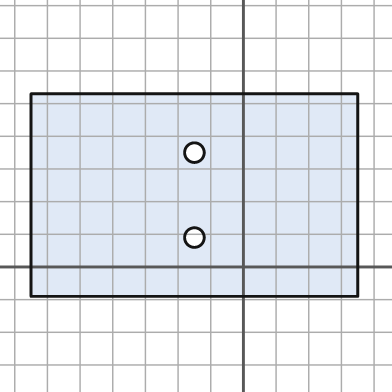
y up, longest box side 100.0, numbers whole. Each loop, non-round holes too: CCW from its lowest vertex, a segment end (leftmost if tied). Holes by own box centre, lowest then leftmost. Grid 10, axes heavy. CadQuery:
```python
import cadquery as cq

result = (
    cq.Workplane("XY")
    .moveTo(-65.0, -9.0)
    .lineTo(35.0, -9.0)
    .lineTo(35.0, 53.0)
    .lineTo(-65.0, 53.0)
    .close()
    .moveTo(-15.0, 9.0)
    .circle(3.0)
    .moveTo(-15.0, 35.0)
    .circle(3.0)
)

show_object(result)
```